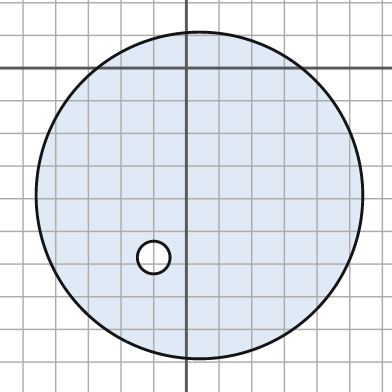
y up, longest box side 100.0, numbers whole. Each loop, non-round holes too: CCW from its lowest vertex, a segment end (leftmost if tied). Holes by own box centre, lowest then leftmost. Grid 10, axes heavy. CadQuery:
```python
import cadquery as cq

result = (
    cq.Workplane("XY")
    .moveTo(4.0, -39.0)
    .circle(50.0)
    .moveTo(-10.0, -58.0)
    .circle(5.0)
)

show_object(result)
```